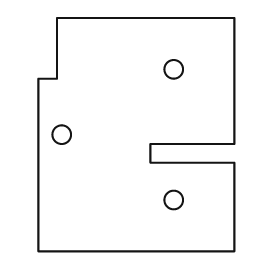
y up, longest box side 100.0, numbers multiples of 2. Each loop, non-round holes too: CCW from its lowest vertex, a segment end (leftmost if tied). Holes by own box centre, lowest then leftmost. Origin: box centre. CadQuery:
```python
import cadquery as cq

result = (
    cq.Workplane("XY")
    .moveTo(-42.0, -50.0)
    .lineTo(42.0, -50.0)
    .lineTo(42.0, -12.0)
    .lineTo(6.0, -12.0)
    .lineTo(6.0, -4.0)
    .lineTo(42.0, -4.0)
    .lineTo(42.0, 50.0)
    .lineTo(-34.0, 50.0)
    .lineTo(-34.0, 24.0)
    .lineTo(-42.0, 24.0)
    .close()
    .moveTo(16.0, -28.0)
    .circle(4.0)
    .moveTo(-32.0, 0.0)
    .circle(4.0)
    .moveTo(16.0, 28.0)
    .circle(4.0)
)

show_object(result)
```